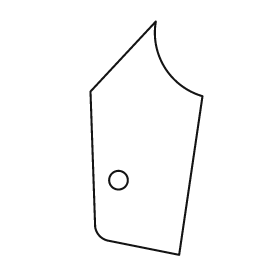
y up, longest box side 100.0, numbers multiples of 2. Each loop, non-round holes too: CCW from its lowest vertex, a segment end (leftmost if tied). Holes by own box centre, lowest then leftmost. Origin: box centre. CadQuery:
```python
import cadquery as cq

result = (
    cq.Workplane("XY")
    .moveTo(14.0, -50.0)
    .lineTo(24.0, 18.0)
    .threePointArc((8.0, 30.0), (4.0, 50.0))
    .lineTo(-24.0, 20.0)
    .lineTo(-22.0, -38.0)
    .threePointArc((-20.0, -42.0), (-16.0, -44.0))
    .close()
    .moveTo(-12.0, -18.0)
    .circle(4.0)
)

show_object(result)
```